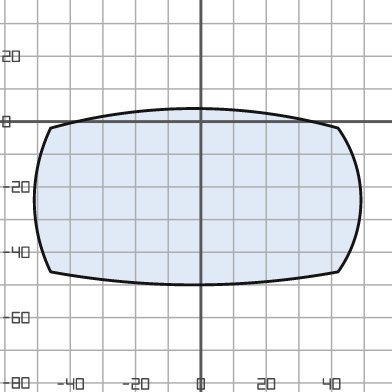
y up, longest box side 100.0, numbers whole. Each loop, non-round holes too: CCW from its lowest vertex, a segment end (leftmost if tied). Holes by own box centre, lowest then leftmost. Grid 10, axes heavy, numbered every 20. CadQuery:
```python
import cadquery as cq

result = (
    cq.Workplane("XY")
    .moveTo(-46.0, -46.0)
    .threePointArc((-2.0, -50.0), (42.0, -46.0))
    .threePointArc((49.0, -24.0), (42.0, -2.0))
    .threePointArc((-2.0, 4.0), (-46.0, -2.0))
    .threePointArc((-51.0, -24.0), (-46.0, -46.0))
    .close()
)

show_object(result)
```